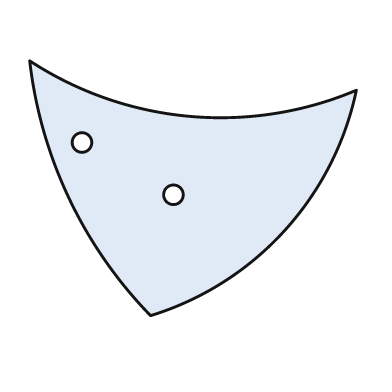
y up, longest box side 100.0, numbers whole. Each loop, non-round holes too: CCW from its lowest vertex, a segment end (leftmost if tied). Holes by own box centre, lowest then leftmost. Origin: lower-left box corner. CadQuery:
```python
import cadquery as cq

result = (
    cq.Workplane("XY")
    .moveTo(37.0, 0.0)
    .threePointArc((78.0, 26.0), (100.0, 69.0))
    .threePointArc((49.0, 61.0), (0.0, 78.0))
    .threePointArc((12.0, 36.0), (37.0, 0.0))
    .close()
    .moveTo(44.0, 37.0)
    .circle(3.0)
    .moveTo(16.0, 53.0)
    .circle(3.0)
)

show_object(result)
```